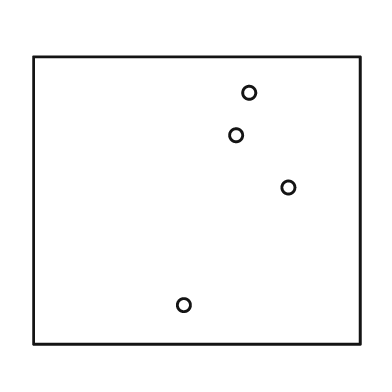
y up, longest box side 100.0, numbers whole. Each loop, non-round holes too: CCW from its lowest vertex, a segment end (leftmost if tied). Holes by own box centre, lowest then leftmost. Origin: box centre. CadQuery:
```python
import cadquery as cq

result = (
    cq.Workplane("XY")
    .moveTo(-50.0, -44.0)
    .lineTo(50.0, -44.0)
    .lineTo(50.0, 44.0)
    .lineTo(-50.0, 44.0)
    .close()
    .moveTo(-4.0, -32.0)
    .circle(2.0)
    .moveTo(28.0, 4.0)
    .circle(2.0)
    .moveTo(12.0, 20.0)
    .circle(2.0)
    .moveTo(16.0, 33.0)
    .circle(2.0)
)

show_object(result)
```